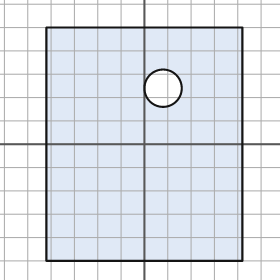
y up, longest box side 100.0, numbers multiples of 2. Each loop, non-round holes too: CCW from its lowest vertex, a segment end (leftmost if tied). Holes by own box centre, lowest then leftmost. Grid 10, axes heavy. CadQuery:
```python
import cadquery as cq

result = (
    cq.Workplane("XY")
    .moveTo(-42.0, -50.0)
    .lineTo(42.0, -50.0)
    .lineTo(42.0, 50.0)
    .lineTo(-42.0, 50.0)
    .close()
    .moveTo(8.0, 24.0)
    .circle(8.0)
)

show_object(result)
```